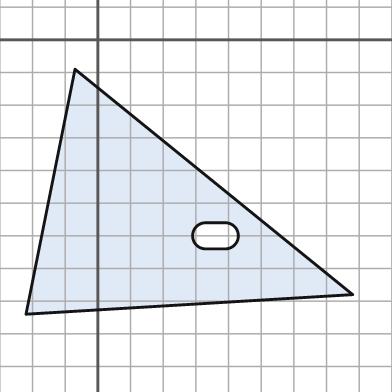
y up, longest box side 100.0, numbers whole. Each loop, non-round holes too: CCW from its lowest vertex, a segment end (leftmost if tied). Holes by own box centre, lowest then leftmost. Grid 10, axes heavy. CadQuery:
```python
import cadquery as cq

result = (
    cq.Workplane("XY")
    .moveTo(-22.0, -84.0)
    .lineTo(78.0, -78.0)
    .lineTo(-7.0, -9.0)
    .close()
    .moveTo(33.0, -64.0)
    .lineTo(39.0, -64.0)
    .threePointArc((43.0, -60.0), (39.0, -56.0))
    .lineTo(33.0, -56.0)
    .threePointArc((29.0, -60.0), (33.0, -64.0))
    .close()
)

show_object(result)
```